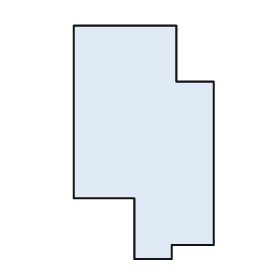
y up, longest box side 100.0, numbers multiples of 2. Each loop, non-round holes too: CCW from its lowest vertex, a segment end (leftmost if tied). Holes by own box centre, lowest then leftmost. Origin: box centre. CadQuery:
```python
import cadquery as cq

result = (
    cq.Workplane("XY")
    .moveTo(-4.0, -50.0)
    .lineTo(12.0, -50.0)
    .lineTo(12.0, -44.0)
    .lineTo(30.0, -44.0)
    .lineTo(30.0, 26.0)
    .lineTo(14.0, 26.0)
    .lineTo(14.0, 50.0)
    .lineTo(-30.0, 50.0)
    .lineTo(-30.0, -24.0)
    .lineTo(-4.0, -24.0)
    .close()
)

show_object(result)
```